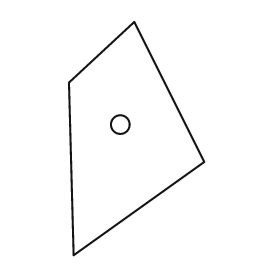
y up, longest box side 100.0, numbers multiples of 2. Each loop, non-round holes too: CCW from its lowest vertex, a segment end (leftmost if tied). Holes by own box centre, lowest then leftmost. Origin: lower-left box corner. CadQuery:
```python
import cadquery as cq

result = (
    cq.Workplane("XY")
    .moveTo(2.0, 0.0)
    .lineTo(58.0, 40.0)
    .lineTo(28.0, 100.0)
    .lineTo(0.0, 74.0)
    .close()
    .moveTo(22.0, 56.0)
    .circle(4.0)
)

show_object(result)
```